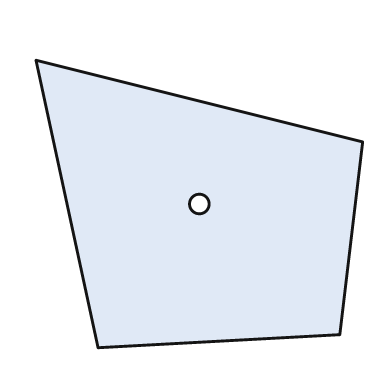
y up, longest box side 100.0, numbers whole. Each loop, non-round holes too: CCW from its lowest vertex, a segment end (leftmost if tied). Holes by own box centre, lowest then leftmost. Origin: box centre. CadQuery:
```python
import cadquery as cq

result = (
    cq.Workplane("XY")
    .moveTo(-31.0, -44.0)
    .lineTo(43.0, -40.0)
    .lineTo(50.0, 19.0)
    .lineTo(-50.0, 44.0)
    .close()
    .moveTo(0.0, 0.0)
    .circle(3.0)
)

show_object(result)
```